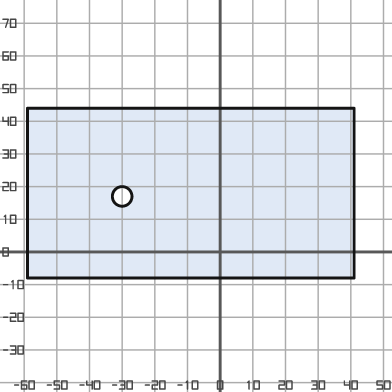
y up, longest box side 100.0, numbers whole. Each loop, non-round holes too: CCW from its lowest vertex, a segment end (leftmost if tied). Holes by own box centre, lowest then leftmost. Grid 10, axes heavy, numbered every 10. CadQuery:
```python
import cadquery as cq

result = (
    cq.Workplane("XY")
    .moveTo(-59.0, -8.0)
    .lineTo(41.0, -8.0)
    .lineTo(41.0, 44.0)
    .lineTo(-59.0, 44.0)
    .close()
    .moveTo(-30.0, 17.0)
    .circle(3.0)
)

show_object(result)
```